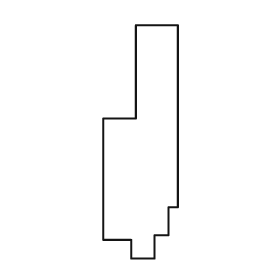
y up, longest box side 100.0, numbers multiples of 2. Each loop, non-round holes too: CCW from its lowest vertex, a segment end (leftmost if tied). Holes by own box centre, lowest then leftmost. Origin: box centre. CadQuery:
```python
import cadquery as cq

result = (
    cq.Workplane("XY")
    .moveTo(-4.0, -50.0)
    .lineTo(6.0, -50.0)
    .lineTo(6.0, -40.0)
    .lineTo(12.0, -40.0)
    .lineTo(12.0, -28.0)
    .lineTo(16.0, -28.0)
    .lineTo(16.0, 50.0)
    .lineTo(-2.0, 50.0)
    .lineTo(-2.0, 10.0)
    .lineTo(-16.0, 10.0)
    .lineTo(-16.0, -42.0)
    .lineTo(-4.0, -42.0)
    .close()
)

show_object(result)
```